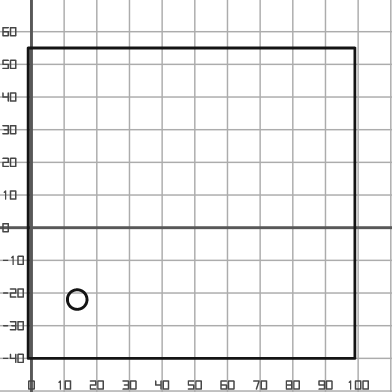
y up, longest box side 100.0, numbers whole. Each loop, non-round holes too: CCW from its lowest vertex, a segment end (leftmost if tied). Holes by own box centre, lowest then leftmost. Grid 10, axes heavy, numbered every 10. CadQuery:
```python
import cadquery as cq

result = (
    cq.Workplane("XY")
    .moveTo(-1.0, -40.0)
    .lineTo(99.0, -40.0)
    .lineTo(99.0, 55.0)
    .lineTo(-1.0, 55.0)
    .close()
    .moveTo(14.0, -22.0)
    .circle(3.0)
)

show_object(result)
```